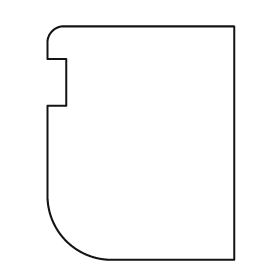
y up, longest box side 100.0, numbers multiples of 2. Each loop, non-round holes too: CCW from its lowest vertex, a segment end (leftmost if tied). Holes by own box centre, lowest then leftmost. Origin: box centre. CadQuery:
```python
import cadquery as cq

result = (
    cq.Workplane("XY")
    .moveTo(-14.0, -50.0)
    .lineTo(40.0, -50.0)
    .lineTo(40.0, 50.0)
    .lineTo(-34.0, 50.0)
    .threePointArc((-38.0, 48.0), (-40.0, 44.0))
    .lineTo(-40.0, 36.0)
    .lineTo(-32.0, 36.0)
    .lineTo(-32.0, 16.0)
    .lineTo(-40.0, 16.0)
    .lineTo(-40.0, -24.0)
    .threePointArc((-32.0, -42.0), (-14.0, -50.0))
    .close()
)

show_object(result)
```